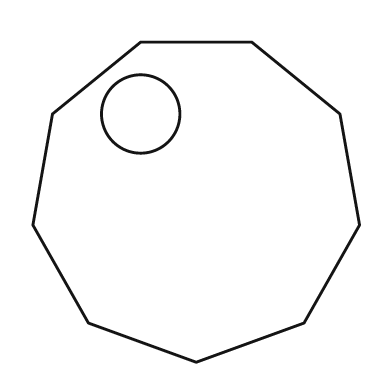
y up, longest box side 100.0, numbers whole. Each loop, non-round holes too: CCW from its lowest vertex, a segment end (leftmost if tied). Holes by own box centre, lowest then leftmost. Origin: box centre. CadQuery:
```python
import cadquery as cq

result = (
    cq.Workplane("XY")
    .moveTo(0.0, -49.0)
    .lineTo(33.0, -37.0)
    .lineTo(50.0, -7.0)
    .lineTo(44.0, 27.0)
    .lineTo(17.0, 49.0)
    .lineTo(-17.0, 49.0)
    .lineTo(-44.0, 27.0)
    .lineTo(-50.0, -7.0)
    .lineTo(-33.0, -37.0)
    .close()
    .moveTo(-17.0, 27.0)
    .circle(12.0)
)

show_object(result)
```